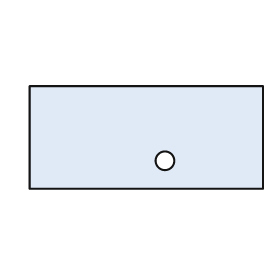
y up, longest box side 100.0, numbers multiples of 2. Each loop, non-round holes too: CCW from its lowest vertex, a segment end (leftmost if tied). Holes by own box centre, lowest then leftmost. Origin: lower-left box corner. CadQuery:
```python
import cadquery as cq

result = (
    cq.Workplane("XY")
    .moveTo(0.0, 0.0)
    .lineTo(100.0, 0.0)
    .lineTo(100.0, 44.0)
    .lineTo(0.0, 44.0)
    .close()
    .moveTo(58.0, 12.0)
    .circle(4.0)
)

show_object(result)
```